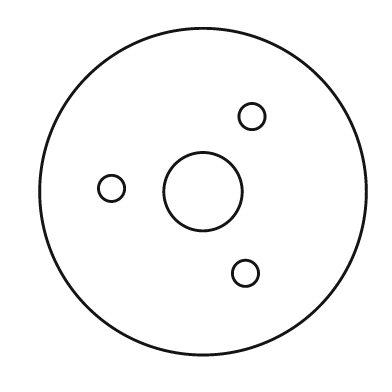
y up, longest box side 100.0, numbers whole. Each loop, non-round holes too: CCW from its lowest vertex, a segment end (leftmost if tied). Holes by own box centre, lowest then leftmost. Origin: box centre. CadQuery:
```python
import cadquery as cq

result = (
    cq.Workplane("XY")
    .moveTo(0.0, 0.0)
    .circle(50.0)
    .moveTo(13.0, -25.0)
    .circle(4.0)
    .moveTo(0.0, 0.0)
    .circle(12.0)
    .moveTo(-28.0, 1.0)
    .circle(4.0)
    .moveTo(15.0, 23.0)
    .circle(4.0)
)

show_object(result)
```